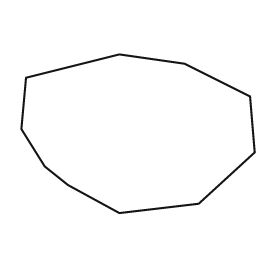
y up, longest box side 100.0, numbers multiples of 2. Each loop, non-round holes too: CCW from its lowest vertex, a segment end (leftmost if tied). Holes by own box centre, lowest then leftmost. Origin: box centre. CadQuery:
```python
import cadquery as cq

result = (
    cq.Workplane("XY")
    .moveTo(-8.0, -34.0)
    .lineTo(26.0, -30.0)
    .lineTo(50.0, -8.0)
    .lineTo(48.0, 16.0)
    .lineTo(20.0, 30.0)
    .lineTo(-8.0, 34.0)
    .lineTo(-48.0, 24.0)
    .lineTo(-50.0, 2.0)
    .lineTo(-40.0, -14.0)
    .lineTo(-30.0, -22.0)
    .close()
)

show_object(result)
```